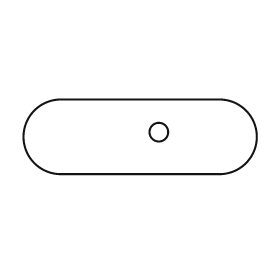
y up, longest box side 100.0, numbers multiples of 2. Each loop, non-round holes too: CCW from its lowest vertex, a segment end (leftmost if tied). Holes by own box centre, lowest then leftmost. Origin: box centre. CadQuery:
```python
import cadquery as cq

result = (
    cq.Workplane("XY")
    .moveTo(-34.0, -16.0)
    .lineTo(34.0, -16.0)
    .threePointArc((50.0, 0.0), (34.0, 16.0))
    .lineTo(-34.0, 16.0)
    .threePointArc((-50.0, 0.0), (-34.0, -16.0))
    .close()
    .moveTo(8.0, 2.0)
    .circle(4.0)
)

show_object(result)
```